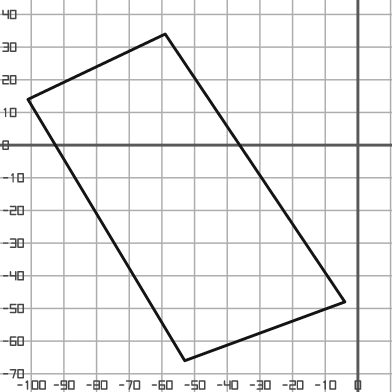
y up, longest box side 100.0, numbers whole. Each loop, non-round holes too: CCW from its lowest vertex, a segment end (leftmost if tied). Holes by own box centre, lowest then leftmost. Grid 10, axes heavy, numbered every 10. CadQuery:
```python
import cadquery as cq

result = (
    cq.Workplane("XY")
    .moveTo(-53.0, -66.0)
    .lineTo(-4.0, -48.0)
    .lineTo(-59.0, 34.0)
    .lineTo(-101.0, 14.0)
    .close()
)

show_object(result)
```